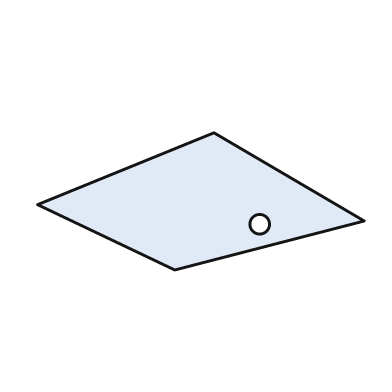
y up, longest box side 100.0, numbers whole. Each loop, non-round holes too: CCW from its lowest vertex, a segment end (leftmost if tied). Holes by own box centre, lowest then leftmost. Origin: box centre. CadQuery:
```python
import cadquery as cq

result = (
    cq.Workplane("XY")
    .moveTo(-8.0, -21.0)
    .lineTo(50.0, -6.0)
    .lineTo(4.0, 21.0)
    .lineTo(-50.0, -1.0)
    .close()
    .moveTo(18.0, -7.0)
    .circle(3.0)
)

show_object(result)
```